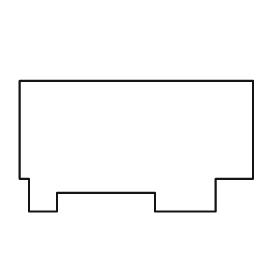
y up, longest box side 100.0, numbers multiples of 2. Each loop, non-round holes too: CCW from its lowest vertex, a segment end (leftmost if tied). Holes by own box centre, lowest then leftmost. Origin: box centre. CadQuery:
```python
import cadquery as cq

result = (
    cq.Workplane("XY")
    .moveTo(-46.0, -28.0)
    .lineTo(-34.0, -28.0)
    .lineTo(-34.0, -20.0)
    .lineTo(8.0, -20.0)
    .lineTo(8.0, -28.0)
    .lineTo(34.0, -28.0)
    .lineTo(34.0, -14.0)
    .lineTo(50.0, -14.0)
    .lineTo(50.0, 28.0)
    .lineTo(-50.0, 28.0)
    .lineTo(-50.0, -14.0)
    .lineTo(-46.0, -14.0)
    .close()
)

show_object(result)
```